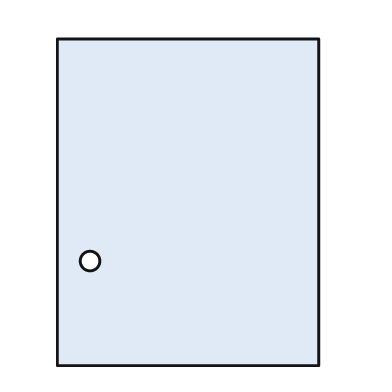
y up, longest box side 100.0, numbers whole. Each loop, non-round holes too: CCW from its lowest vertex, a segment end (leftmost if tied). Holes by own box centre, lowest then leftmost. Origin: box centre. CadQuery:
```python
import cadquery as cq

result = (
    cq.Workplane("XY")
    .moveTo(-40.0, -50.0)
    .lineTo(40.0, -50.0)
    .lineTo(40.0, 50.0)
    .lineTo(-40.0, 50.0)
    .close()
    .moveTo(-30.0, -18.0)
    .circle(3.0)
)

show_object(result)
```